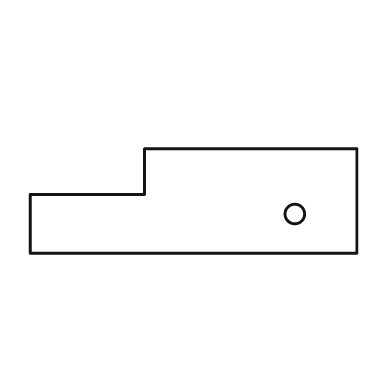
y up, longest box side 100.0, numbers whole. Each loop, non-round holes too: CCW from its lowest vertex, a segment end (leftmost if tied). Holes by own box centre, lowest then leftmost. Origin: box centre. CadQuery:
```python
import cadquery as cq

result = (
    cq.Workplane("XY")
    .moveTo(-50.0, -16.0)
    .lineTo(50.0, -16.0)
    .lineTo(50.0, 16.0)
    .lineTo(-15.0, 16.0)
    .lineTo(-15.0, 2.0)
    .lineTo(-50.0, 2.0)
    .close()
    .moveTo(31.0, -4.0)
    .circle(3.0)
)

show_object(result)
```